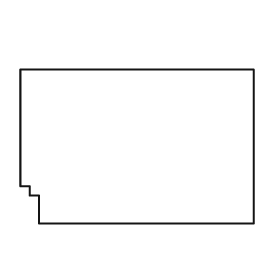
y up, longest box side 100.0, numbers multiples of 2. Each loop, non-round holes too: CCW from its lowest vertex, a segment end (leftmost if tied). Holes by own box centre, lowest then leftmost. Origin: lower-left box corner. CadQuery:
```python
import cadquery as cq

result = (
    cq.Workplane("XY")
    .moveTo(8.0, 0.0)
    .lineTo(100.0, 0.0)
    .lineTo(100.0, 66.0)
    .lineTo(0.0, 66.0)
    .lineTo(0.0, 16.0)
    .lineTo(4.0, 16.0)
    .lineTo(4.0, 12.0)
    .lineTo(8.0, 12.0)
    .close()
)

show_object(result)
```